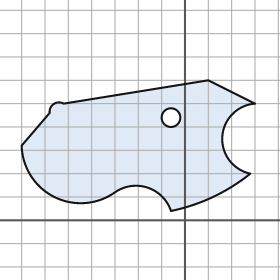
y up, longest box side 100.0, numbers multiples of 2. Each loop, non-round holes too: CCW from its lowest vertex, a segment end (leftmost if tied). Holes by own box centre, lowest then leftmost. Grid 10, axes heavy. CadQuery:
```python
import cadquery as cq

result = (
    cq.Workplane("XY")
    .moveTo(-6.0, 4.0)
    .threePointArc((12.0, 10.0), (28.0, 20.0))
    .threePointArc((16.0, 36.0), (30.0, 50.0))
    .lineTo(10.0, 60.0)
    .lineTo(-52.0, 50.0)
    .threePointArc((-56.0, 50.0), (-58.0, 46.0))
    .lineTo(-70.0, 32.0)
    .threePointArc((-56.0, 10.0), (-30.0, 12.0))
    .threePointArc((-16.0, 14.0), (-6.0, 4.0))
    .close()
    .moveTo(-6.0, 44.0)
    .circle(4.0)
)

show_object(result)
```